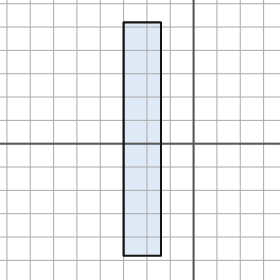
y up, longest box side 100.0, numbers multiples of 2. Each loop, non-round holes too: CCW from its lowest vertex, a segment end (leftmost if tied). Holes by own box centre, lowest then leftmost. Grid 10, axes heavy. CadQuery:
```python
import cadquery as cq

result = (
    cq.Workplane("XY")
    .moveTo(-30.0, -48.0)
    .lineTo(-14.0, -48.0)
    .lineTo(-14.0, 52.0)
    .lineTo(-30.0, 52.0)
    .close()
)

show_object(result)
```